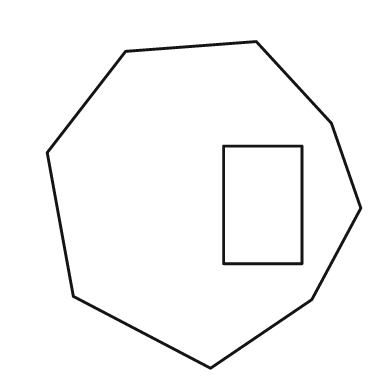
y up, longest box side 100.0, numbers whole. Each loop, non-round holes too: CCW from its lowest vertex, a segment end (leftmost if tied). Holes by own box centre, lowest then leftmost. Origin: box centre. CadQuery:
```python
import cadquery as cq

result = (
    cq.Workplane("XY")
    .moveTo(2.0, -50.0)
    .lineTo(33.0, -29.0)
    .lineTo(48.0, -1.0)
    .lineTo(39.0, 25.0)
    .lineTo(16.0, 50.0)
    .lineTo(-24.0, 47.0)
    .lineTo(-48.0, 16.0)
    .lineTo(-40.0, -28.0)
    .close()
    .moveTo(6.0, -18.0)
    .lineTo(30.0, -18.0)
    .lineTo(30.0, 18.0)
    .lineTo(6.0, 18.0)
    .close()
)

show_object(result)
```